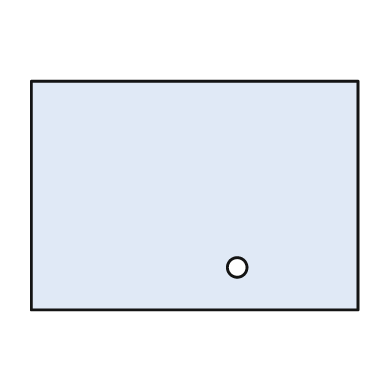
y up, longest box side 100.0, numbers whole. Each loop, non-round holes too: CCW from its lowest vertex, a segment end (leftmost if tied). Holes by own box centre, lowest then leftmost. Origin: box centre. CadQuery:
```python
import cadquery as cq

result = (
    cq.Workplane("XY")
    .moveTo(-50.0, -35.0)
    .lineTo(50.0, -35.0)
    .lineTo(50.0, 35.0)
    .lineTo(-50.0, 35.0)
    .close()
    .moveTo(13.0, -22.0)
    .circle(3.0)
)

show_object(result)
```